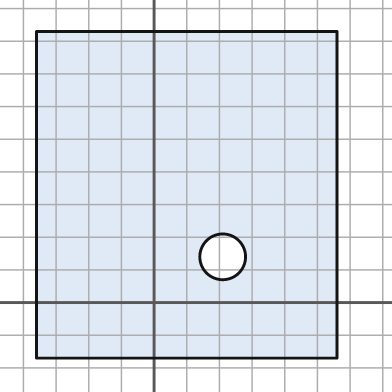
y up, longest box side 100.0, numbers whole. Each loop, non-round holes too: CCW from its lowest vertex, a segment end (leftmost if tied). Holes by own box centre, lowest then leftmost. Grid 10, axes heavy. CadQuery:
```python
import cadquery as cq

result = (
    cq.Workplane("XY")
    .moveTo(-36.0, -17.0)
    .lineTo(56.0, -17.0)
    .lineTo(56.0, 83.0)
    .lineTo(-36.0, 83.0)
    .close()
    .moveTo(21.0, 14.0)
    .circle(7.0)
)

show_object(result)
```